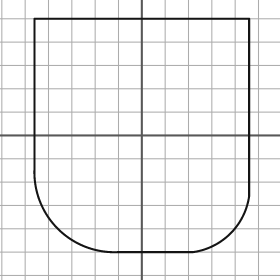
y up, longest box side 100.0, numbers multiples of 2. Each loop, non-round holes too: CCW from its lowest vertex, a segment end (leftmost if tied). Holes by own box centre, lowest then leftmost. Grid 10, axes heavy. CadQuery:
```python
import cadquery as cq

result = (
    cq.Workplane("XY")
    .moveTo(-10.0, -50.0)
    .lineTo(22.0, -50.0)
    .threePointArc((38.0, -42.0), (46.0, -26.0))
    .lineTo(46.0, 50.0)
    .lineTo(-46.0, 50.0)
    .lineTo(-46.0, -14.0)
    .threePointArc((-36.0, -40.0), (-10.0, -50.0))
    .close()
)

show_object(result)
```